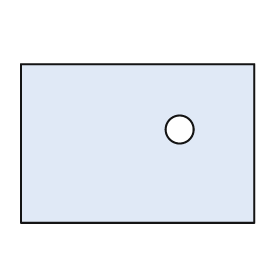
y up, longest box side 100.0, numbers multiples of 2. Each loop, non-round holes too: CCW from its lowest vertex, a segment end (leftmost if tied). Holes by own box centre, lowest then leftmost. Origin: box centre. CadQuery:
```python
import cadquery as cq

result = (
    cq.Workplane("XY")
    .moveTo(-50.0, -34.0)
    .lineTo(50.0, -34.0)
    .lineTo(50.0, 34.0)
    .lineTo(-50.0, 34.0)
    .close()
    .moveTo(18.0, 6.0)
    .circle(6.0)
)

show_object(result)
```